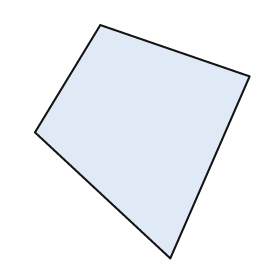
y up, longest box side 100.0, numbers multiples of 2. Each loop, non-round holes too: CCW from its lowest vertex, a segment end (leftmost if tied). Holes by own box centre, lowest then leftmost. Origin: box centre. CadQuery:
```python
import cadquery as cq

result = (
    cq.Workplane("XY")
    .moveTo(12.0, -50.0)
    .lineTo(46.0, 28.0)
    .lineTo(-18.0, 50.0)
    .lineTo(-46.0, 4.0)
    .close()
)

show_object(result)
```